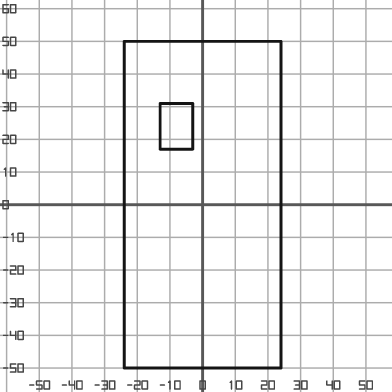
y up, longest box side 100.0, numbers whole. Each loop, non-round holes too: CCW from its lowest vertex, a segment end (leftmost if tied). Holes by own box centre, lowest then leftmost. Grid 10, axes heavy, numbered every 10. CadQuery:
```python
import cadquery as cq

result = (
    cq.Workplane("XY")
    .moveTo(-24.0, -50.0)
    .lineTo(24.0, -50.0)
    .lineTo(24.0, 50.0)
    .lineTo(-24.0, 50.0)
    .close()
    .moveTo(-13.0, 17.0)
    .lineTo(-3.0, 17.0)
    .lineTo(-3.0, 31.0)
    .lineTo(-13.0, 31.0)
    .close()
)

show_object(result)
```